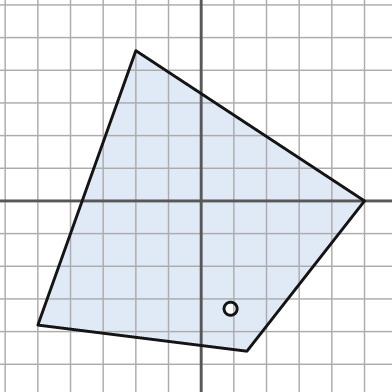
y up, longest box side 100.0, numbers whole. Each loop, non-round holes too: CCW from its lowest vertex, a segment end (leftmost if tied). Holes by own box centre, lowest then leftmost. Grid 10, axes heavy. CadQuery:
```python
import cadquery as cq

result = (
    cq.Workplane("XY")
    .moveTo(14.0, -46.0)
    .lineTo(50.0, 0.0)
    .lineTo(-20.0, 46.0)
    .lineTo(-50.0, -38.0)
    .close()
    .moveTo(9.0, -33.0)
    .circle(2.0)
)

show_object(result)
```